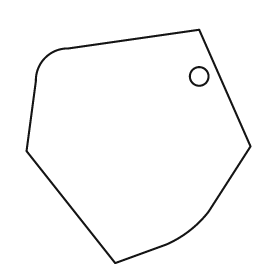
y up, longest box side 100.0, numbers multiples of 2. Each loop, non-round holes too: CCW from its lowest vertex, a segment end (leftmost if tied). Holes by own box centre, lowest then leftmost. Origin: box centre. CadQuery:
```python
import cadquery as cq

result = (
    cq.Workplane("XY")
    .moveTo(-10.0, -50.0)
    .lineTo(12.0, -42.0)
    .threePointArc((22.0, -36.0), (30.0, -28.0))
    .lineTo(48.0, 0.0)
    .lineTo(26.0, 50.0)
    .lineTo(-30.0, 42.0)
    .threePointArc((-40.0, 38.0), (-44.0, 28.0))
    .lineTo(-48.0, -2.0)
    .close()
    .moveTo(26.0, 30.0)
    .circle(4.0)
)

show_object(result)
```